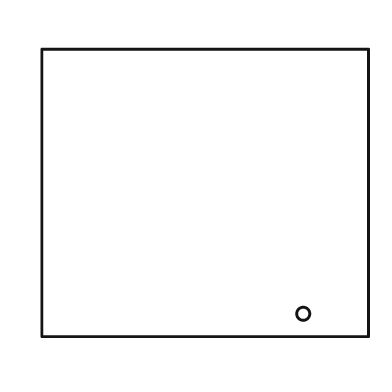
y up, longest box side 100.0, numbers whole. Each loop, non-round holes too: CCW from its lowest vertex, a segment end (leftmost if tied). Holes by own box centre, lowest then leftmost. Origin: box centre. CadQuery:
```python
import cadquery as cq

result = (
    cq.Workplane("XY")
    .moveTo(-50.0, -44.0)
    .lineTo(50.0, -44.0)
    .lineTo(50.0, 44.0)
    .lineTo(-50.0, 44.0)
    .close()
    .moveTo(30.0, -37.0)
    .circle(2.0)
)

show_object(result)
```